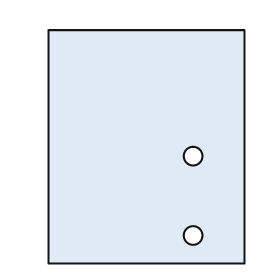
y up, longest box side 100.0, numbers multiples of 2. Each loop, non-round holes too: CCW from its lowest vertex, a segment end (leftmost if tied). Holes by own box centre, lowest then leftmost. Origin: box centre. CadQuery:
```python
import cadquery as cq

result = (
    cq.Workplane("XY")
    .moveTo(-42.0, -50.0)
    .lineTo(42.0, -50.0)
    .lineTo(42.0, 50.0)
    .lineTo(-42.0, 50.0)
    .close()
    .moveTo(20.0, -38.0)
    .circle(4.0)
    .moveTo(20.0, -4.0)
    .circle(4.0)
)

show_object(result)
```